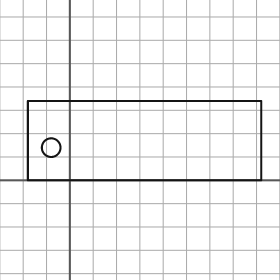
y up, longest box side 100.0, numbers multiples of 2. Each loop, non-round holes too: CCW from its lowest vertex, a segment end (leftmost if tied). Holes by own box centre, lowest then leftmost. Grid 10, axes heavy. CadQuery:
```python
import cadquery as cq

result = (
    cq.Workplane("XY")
    .moveTo(-18.0, 0.0)
    .lineTo(82.0, 0.0)
    .lineTo(82.0, 34.0)
    .lineTo(-18.0, 34.0)
    .close()
    .moveTo(-8.0, 14.0)
    .circle(4.0)
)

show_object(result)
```